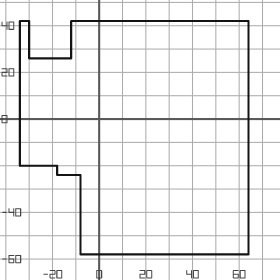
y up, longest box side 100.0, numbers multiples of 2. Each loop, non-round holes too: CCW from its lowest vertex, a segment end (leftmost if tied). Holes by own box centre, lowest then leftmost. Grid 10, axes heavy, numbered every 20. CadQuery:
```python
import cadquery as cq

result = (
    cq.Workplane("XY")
    .moveTo(-8.0, -58.0)
    .lineTo(64.0, -58.0)
    .lineTo(64.0, 42.0)
    .lineTo(-12.0, 42.0)
    .lineTo(-12.0, 26.0)
    .lineTo(-30.0, 26.0)
    .lineTo(-30.0, 42.0)
    .lineTo(-34.0, 42.0)
    .lineTo(-34.0, -20.0)
    .lineTo(-18.0, -20.0)
    .lineTo(-18.0, -24.0)
    .lineTo(-8.0, -24.0)
    .close()
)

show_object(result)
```